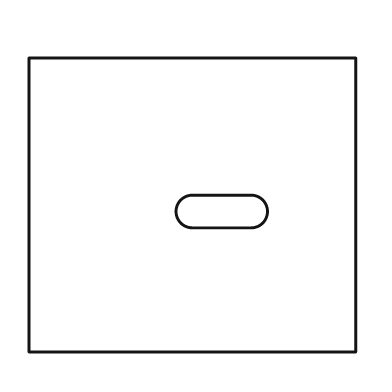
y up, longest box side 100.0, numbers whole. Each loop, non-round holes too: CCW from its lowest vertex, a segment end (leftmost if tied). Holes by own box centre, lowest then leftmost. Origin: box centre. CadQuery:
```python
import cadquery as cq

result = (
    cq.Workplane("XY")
    .moveTo(-50.0, -45.0)
    .lineTo(50.0, -45.0)
    .lineTo(50.0, 45.0)
    .lineTo(-50.0, 45.0)
    .close()
    .moveTo(0.0, -7.0)
    .lineTo(18.0, -7.0)
    .threePointArc((23.0, -2.0), (18.0, 3.0))
    .lineTo(0.0, 3.0)
    .threePointArc((-5.0, -2.0), (0.0, -7.0))
    .close()
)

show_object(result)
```